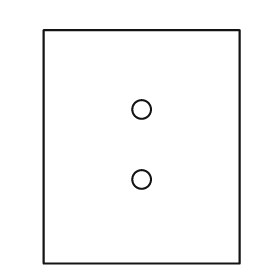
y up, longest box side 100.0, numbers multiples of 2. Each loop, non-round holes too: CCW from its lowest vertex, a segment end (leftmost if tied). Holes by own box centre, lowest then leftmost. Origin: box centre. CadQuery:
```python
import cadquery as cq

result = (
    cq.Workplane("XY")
    .moveTo(-42.0, -50.0)
    .lineTo(42.0, -50.0)
    .lineTo(42.0, 50.0)
    .lineTo(-42.0, 50.0)
    .close()
    .moveTo(0.0, -14.0)
    .circle(4.0)
    .moveTo(0.0, 16.0)
    .circle(4.0)
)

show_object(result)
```